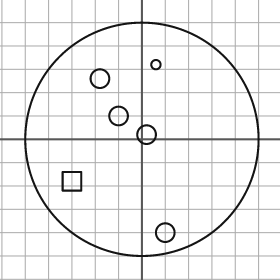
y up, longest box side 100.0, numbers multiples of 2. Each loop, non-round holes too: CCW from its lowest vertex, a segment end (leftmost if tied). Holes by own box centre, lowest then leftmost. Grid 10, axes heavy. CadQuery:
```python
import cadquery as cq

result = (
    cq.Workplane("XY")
    .moveTo(0.0, 0.0)
    .circle(50.0)
    .moveTo(10.0, -40.0)
    .circle(4.0)
    .moveTo(-34.0, -22.0)
    .lineTo(-26.0, -22.0)
    .lineTo(-26.0, -14.0)
    .lineTo(-34.0, -14.0)
    .close()
    .moveTo(2.0, 2.0)
    .circle(4.0)
    .moveTo(-10.0, 10.0)
    .circle(4.0)
    .moveTo(-18.0, 26.0)
    .circle(4.0)
    .moveTo(6.0, 32.0)
    .circle(2.0)
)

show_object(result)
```